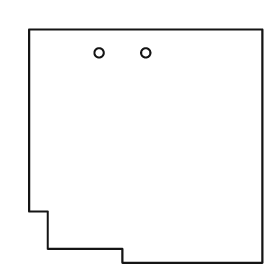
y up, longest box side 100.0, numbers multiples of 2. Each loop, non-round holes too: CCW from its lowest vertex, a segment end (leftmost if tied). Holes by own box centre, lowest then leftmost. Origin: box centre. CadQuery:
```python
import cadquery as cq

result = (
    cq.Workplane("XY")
    .moveTo(-10.0, -50.0)
    .lineTo(50.0, -50.0)
    .lineTo(50.0, 50.0)
    .lineTo(-50.0, 50.0)
    .lineTo(-50.0, -28.0)
    .lineTo(-42.0, -28.0)
    .lineTo(-42.0, -44.0)
    .lineTo(-10.0, -44.0)
    .close()
    .moveTo(-20.0, 40.0)
    .circle(2.0)
    .moveTo(0.0, 40.0)
    .circle(2.0)
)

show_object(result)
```